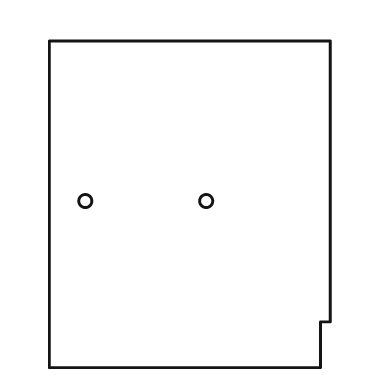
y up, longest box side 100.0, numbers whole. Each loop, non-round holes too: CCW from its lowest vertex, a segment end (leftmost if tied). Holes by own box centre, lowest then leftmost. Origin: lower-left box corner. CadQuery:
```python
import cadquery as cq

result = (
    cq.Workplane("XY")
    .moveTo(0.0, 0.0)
    .lineTo(83.0, 0.0)
    .lineTo(83.0, 14.0)
    .lineTo(86.0, 14.0)
    .lineTo(86.0, 100.0)
    .lineTo(0.0, 100.0)
    .close()
    .moveTo(11.0, 51.0)
    .circle(2.0)
    .moveTo(48.0, 51.0)
    .circle(2.0)
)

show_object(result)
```